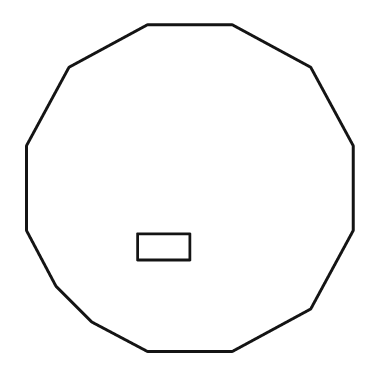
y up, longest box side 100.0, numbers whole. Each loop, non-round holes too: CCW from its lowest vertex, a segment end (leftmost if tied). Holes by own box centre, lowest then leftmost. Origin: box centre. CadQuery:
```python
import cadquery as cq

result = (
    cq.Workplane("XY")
    .moveTo(-13.0, -50.0)
    .lineTo(13.0, -50.0)
    .lineTo(37.0, -37.0)
    .lineTo(50.0, -13.0)
    .lineTo(50.0, 13.0)
    .lineTo(37.0, 37.0)
    .lineTo(13.0, 50.0)
    .lineTo(-13.0, 50.0)
    .lineTo(-37.0, 37.0)
    .lineTo(-50.0, 13.0)
    .lineTo(-50.0, -13.0)
    .lineTo(-41.0, -30.0)
    .lineTo(-30.0, -41.0)
    .close()
    .moveTo(-16.0, -22.0)
    .lineTo(0.0, -22.0)
    .lineTo(0.0, -14.0)
    .lineTo(-16.0, -14.0)
    .close()
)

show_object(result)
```